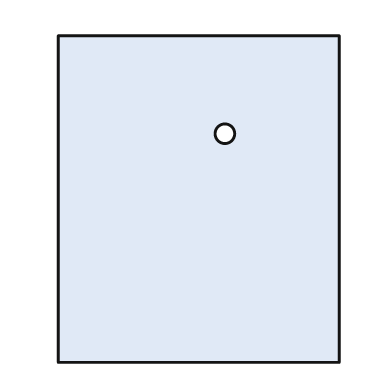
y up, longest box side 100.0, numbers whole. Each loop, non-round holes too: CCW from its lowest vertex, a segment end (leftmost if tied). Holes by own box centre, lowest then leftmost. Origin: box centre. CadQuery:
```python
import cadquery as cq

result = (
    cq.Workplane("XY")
    .moveTo(-43.0, -50.0)
    .lineTo(43.0, -50.0)
    .lineTo(43.0, 50.0)
    .lineTo(-43.0, 50.0)
    .close()
    .moveTo(8.0, 20.0)
    .circle(3.0)
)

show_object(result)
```